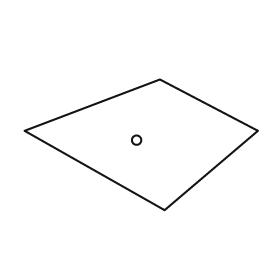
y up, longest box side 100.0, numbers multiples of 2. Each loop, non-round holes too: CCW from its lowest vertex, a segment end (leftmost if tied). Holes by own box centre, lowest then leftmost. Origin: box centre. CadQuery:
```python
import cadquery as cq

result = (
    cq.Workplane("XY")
    .moveTo(10.0, -28.0)
    .lineTo(50.0, 6.0)
    .lineTo(8.0, 28.0)
    .lineTo(-50.0, 6.0)
    .close()
    .moveTo(-2.0, 2.0)
    .circle(2.0)
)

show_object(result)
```